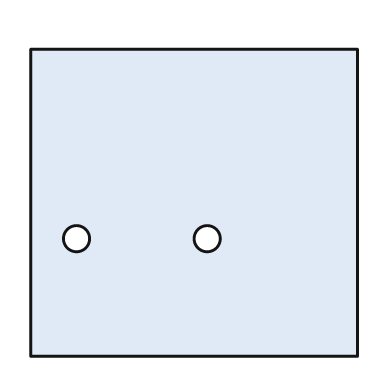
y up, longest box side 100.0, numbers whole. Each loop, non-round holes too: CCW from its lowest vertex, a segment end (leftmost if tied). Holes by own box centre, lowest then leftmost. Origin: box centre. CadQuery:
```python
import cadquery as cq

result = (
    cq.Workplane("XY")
    .moveTo(-50.0, -47.0)
    .lineTo(50.0, -47.0)
    .lineTo(50.0, 47.0)
    .lineTo(-50.0, 47.0)
    .close()
    .moveTo(-36.0, -11.0)
    .circle(4.0)
    .moveTo(4.0, -11.0)
    .circle(4.0)
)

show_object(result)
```